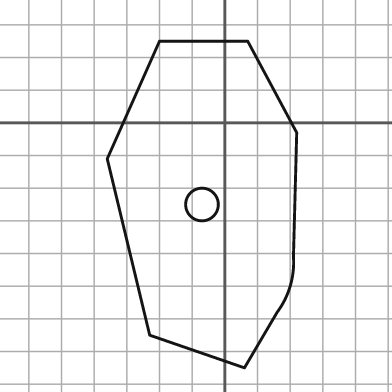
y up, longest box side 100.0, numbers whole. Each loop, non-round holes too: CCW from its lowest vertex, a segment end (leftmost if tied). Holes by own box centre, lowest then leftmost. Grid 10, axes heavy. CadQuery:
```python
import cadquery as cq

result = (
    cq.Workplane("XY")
    .moveTo(6.0, -75.0)
    .lineTo(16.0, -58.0)
    .threePointArc((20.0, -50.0), (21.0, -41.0))
    .lineTo(22.0, -3.0)
    .lineTo(7.0, 25.0)
    .lineTo(-20.0, 25.0)
    .lineTo(-36.0, -11.0)
    .lineTo(-23.0, -65.0)
    .close()
    .moveTo(-7.0, -25.0)
    .circle(5.0)
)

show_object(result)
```